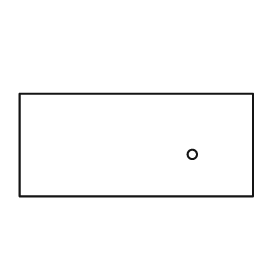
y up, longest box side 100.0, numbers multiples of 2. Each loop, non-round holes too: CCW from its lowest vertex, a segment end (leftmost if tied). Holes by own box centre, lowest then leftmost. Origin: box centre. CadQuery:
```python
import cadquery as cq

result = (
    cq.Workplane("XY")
    .moveTo(-50.0, -22.0)
    .lineTo(50.0, -22.0)
    .lineTo(50.0, 22.0)
    .lineTo(-50.0, 22.0)
    .close()
    .moveTo(24.0, -4.0)
    .circle(2.0)
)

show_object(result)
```